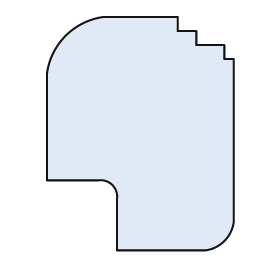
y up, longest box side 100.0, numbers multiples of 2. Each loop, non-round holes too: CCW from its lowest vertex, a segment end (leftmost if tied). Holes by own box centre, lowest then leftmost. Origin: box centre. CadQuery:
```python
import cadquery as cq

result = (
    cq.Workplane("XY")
    .moveTo(-10.0, -50.0)
    .lineTo(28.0, -50.0)
    .threePointArc((36.0, -46.0), (40.0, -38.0))
    .lineTo(40.0, 32.0)
    .lineTo(36.0, 32.0)
    .lineTo(36.0, 38.0)
    .lineTo(24.0, 38.0)
    .lineTo(24.0, 44.0)
    .lineTo(16.0, 44.0)
    .lineTo(16.0, 50.0)
    .lineTo(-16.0, 50.0)
    .threePointArc((-32.0, 42.0), (-40.0, 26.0))
    .lineTo(-40.0, -20.0)
    .lineTo(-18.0, -20.0)
    .threePointArc((-12.0, -22.0), (-10.0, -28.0))
    .close()
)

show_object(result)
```